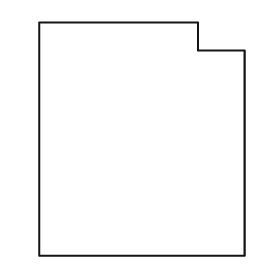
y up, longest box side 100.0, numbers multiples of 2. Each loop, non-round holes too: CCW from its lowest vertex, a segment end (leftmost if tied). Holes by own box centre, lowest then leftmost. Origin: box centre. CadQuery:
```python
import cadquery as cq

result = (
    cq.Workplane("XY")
    .moveTo(-44.0, -50.0)
    .lineTo(44.0, -50.0)
    .lineTo(44.0, 38.0)
    .lineTo(24.0, 38.0)
    .lineTo(24.0, 50.0)
    .lineTo(-44.0, 50.0)
    .close()
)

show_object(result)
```